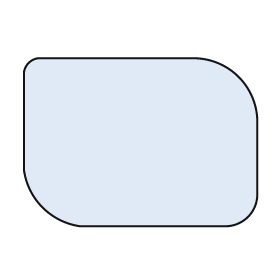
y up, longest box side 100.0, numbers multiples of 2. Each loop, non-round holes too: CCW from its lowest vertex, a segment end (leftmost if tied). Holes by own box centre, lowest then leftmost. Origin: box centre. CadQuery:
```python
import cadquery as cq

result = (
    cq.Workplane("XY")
    .moveTo(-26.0, -36.0)
    .lineTo(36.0, -36.0)
    .threePointArc((46.0, -32.0), (50.0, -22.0))
    .lineTo(50.0, 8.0)
    .threePointArc((42.0, 28.0), (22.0, 36.0))
    .lineTo(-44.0, 36.0)
    .threePointArc((-48.0, 34.0), (-50.0, 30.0))
    .lineTo(-50.0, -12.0)
    .threePointArc((-42.0, -28.0), (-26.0, -36.0))
    .close()
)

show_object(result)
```